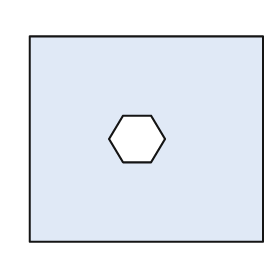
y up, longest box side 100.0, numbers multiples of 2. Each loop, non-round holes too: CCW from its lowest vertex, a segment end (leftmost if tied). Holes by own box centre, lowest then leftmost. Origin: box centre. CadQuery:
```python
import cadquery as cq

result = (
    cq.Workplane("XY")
    .moveTo(-50.0, -44.0)
    .lineTo(50.0, -44.0)
    .lineTo(50.0, 44.0)
    .lineTo(-50.0, 44.0)
    .close()
    .moveTo(-10.0, -10.0)
    .lineTo(2.0, -10.0)
    .lineTo(8.0, 0.0)
    .lineTo(2.0, 10.0)
    .lineTo(-10.0, 10.0)
    .lineTo(-16.0, 0.0)
    .close()
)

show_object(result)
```